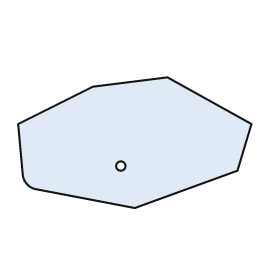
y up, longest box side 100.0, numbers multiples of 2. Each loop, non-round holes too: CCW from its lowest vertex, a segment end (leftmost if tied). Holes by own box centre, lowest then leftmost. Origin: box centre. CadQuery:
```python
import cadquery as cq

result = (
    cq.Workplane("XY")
    .moveTo(0.0, -28.0)
    .lineTo(44.0, -12.0)
    .lineTo(50.0, 8.0)
    .lineTo(14.0, 28.0)
    .lineTo(-18.0, 24.0)
    .lineTo(-50.0, 8.0)
    .lineTo(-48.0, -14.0)
    .threePointArc((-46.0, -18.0), (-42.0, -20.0))
    .close()
    .moveTo(-6.0, -10.0)
    .circle(2.0)
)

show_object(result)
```